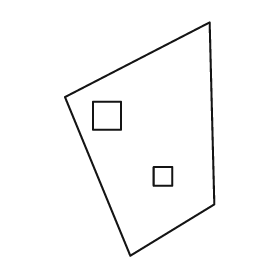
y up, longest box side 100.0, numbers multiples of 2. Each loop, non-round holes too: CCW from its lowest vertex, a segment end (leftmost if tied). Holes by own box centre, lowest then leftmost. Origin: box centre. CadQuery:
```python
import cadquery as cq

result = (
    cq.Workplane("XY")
    .moveTo(-4.0, -50.0)
    .lineTo(32.0, -28.0)
    .lineTo(30.0, 50.0)
    .lineTo(-32.0, 18.0)
    .close()
    .moveTo(6.0, -20.0)
    .lineTo(14.0, -20.0)
    .lineTo(14.0, -12.0)
    .lineTo(6.0, -12.0)
    .close()
    .moveTo(-20.0, 4.0)
    .lineTo(-8.0, 4.0)
    .lineTo(-8.0, 16.0)
    .lineTo(-20.0, 16.0)
    .close()
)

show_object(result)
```